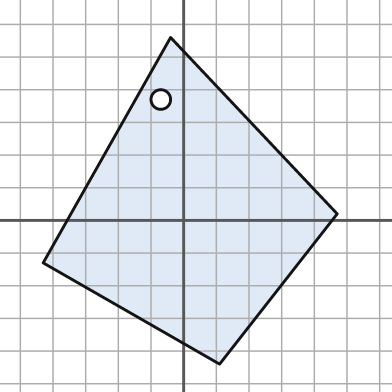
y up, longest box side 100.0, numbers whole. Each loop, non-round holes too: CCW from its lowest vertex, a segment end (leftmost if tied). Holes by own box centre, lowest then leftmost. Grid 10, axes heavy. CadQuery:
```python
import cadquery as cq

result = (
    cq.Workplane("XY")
    .moveTo(11.0, -44.0)
    .lineTo(47.0, 2.0)
    .lineTo(-4.0, 56.0)
    .lineTo(-43.0, -13.0)
    .close()
    .moveTo(-7.0, 37.0)
    .circle(3.0)
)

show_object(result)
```